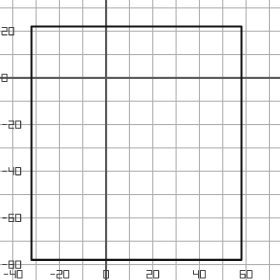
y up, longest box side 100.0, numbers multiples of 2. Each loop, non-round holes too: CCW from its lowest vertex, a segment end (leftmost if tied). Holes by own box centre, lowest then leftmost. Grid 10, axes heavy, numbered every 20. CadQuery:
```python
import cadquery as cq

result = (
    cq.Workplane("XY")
    .moveTo(-32.0, -78.0)
    .lineTo(58.0, -78.0)
    .lineTo(58.0, 22.0)
    .lineTo(-32.0, 22.0)
    .close()
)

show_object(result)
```